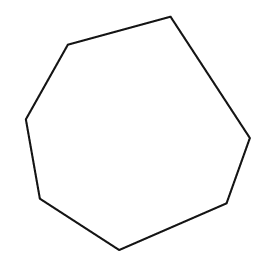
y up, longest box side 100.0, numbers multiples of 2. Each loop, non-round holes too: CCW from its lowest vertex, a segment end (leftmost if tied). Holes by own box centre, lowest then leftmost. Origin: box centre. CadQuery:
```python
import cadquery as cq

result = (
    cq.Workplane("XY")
    .moveTo(-8.0, -50.0)
    .lineTo(38.0, -30.0)
    .lineTo(48.0, -2.0)
    .lineTo(14.0, 50.0)
    .lineTo(-30.0, 38.0)
    .lineTo(-48.0, 6.0)
    .lineTo(-42.0, -28.0)
    .close()
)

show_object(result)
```